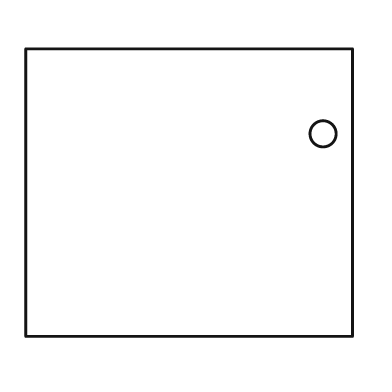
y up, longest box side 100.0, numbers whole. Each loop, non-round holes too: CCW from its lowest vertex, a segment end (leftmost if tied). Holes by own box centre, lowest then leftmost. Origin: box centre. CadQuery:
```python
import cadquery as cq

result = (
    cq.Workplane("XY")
    .moveTo(-50.0, -44.0)
    .lineTo(50.0, -44.0)
    .lineTo(50.0, 44.0)
    .lineTo(-50.0, 44.0)
    .close()
    .moveTo(41.0, 18.0)
    .circle(4.0)
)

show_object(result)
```